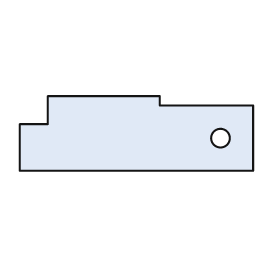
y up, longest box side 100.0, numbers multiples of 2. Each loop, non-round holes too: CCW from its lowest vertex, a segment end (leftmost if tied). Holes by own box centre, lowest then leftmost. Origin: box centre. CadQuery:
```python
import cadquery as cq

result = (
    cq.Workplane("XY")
    .moveTo(-50.0, -16.0)
    .lineTo(50.0, -16.0)
    .lineTo(50.0, 12.0)
    .lineTo(10.0, 12.0)
    .lineTo(10.0, 16.0)
    .lineTo(-38.0, 16.0)
    .lineTo(-38.0, 4.0)
    .lineTo(-50.0, 4.0)
    .close()
    .moveTo(36.0, -2.0)
    .circle(4.0)
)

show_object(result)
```